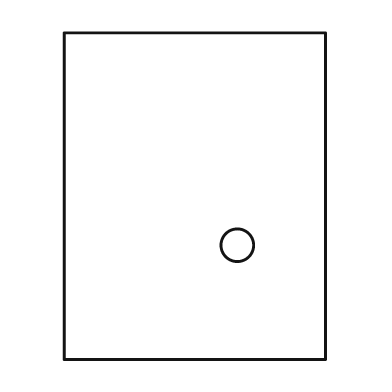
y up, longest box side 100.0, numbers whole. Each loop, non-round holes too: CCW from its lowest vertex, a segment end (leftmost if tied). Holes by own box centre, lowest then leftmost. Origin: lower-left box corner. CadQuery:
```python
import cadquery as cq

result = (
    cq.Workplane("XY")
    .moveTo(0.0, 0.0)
    .lineTo(80.0, 0.0)
    .lineTo(80.0, 100.0)
    .lineTo(0.0, 100.0)
    .close()
    .moveTo(53.0, 35.0)
    .circle(5.0)
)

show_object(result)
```